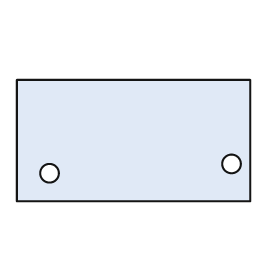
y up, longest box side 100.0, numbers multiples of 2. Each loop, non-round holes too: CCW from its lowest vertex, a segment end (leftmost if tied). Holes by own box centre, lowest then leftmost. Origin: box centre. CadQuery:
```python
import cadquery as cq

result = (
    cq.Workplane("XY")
    .moveTo(-50.0, -26.0)
    .lineTo(50.0, -26.0)
    .lineTo(50.0, 26.0)
    .lineTo(-50.0, 26.0)
    .close()
    .moveTo(-36.0, -14.0)
    .circle(4.0)
    .moveTo(42.0, -10.0)
    .circle(4.0)
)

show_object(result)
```